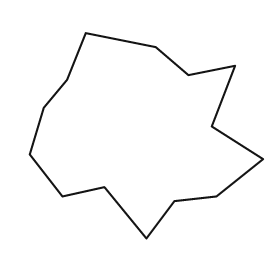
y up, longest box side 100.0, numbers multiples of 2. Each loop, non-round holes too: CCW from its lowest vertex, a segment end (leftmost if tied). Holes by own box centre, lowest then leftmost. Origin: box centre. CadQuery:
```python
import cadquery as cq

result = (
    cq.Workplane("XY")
    .moveTo(0.0, -44.0)
    .lineTo(12.0, -28.0)
    .lineTo(30.0, -26.0)
    .lineTo(50.0, -10.0)
    .lineTo(28.0, 4.0)
    .lineTo(38.0, 30.0)
    .lineTo(18.0, 26.0)
    .lineTo(4.0, 38.0)
    .lineTo(-26.0, 44.0)
    .lineTo(-34.0, 24.0)
    .lineTo(-44.0, 12.0)
    .lineTo(-50.0, -8.0)
    .lineTo(-36.0, -26.0)
    .lineTo(-18.0, -22.0)
    .close()
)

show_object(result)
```